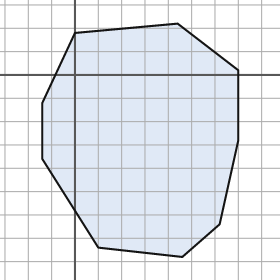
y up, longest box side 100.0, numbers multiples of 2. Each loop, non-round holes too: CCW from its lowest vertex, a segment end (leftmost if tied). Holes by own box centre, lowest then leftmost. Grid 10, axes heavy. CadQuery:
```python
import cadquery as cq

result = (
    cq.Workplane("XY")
    .moveTo(46.0, -78.0)
    .lineTo(62.0, -64.0)
    .lineTo(70.0, -28.0)
    .lineTo(70.0, 2.0)
    .lineTo(44.0, 22.0)
    .lineTo(0.0, 18.0)
    .lineTo(-14.0, -12.0)
    .lineTo(-14.0, -36.0)
    .lineTo(10.0, -74.0)
    .close()
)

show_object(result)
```